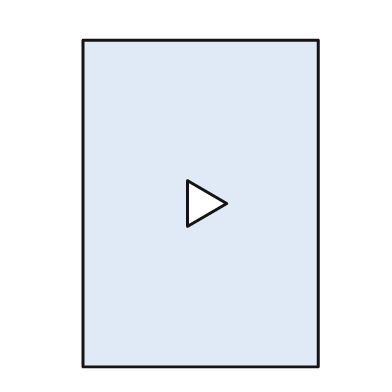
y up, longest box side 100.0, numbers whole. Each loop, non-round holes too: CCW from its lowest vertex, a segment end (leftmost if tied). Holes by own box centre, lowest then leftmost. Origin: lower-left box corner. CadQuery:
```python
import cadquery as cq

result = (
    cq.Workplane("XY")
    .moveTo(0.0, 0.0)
    .lineTo(72.0, 0.0)
    .lineTo(72.0, 100.0)
    .lineTo(0.0, 100.0)
    .close()
    .moveTo(32.0, 43.0)
    .lineTo(44.0, 50.0)
    .lineTo(32.0, 57.0)
    .close()
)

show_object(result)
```